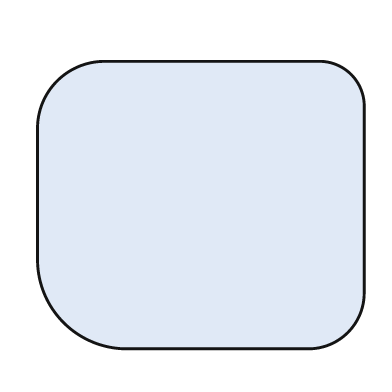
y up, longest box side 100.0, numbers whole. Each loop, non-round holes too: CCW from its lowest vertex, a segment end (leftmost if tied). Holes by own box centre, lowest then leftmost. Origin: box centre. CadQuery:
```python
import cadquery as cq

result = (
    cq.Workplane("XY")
    .moveTo(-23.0, -44.0)
    .lineTo(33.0, -44.0)
    .threePointArc((45.0, -39.0), (50.0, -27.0))
    .lineTo(50.0, 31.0)
    .threePointArc((46.0, 40.0), (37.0, 44.0))
    .lineTo(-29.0, 44.0)
    .threePointArc((-44.0, 38.0), (-50.0, 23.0))
    .lineTo(-50.0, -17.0)
    .threePointArc((-42.0, -36.0), (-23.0, -44.0))
    .close()
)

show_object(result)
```